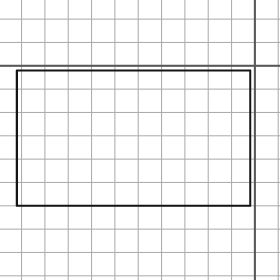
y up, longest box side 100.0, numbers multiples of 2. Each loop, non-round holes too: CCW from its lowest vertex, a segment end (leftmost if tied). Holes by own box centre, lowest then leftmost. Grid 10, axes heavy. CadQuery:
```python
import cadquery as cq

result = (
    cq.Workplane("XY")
    .moveTo(-102.0, -60.0)
    .lineTo(-2.0, -60.0)
    .lineTo(-2.0, -2.0)
    .lineTo(-102.0, -2.0)
    .close()
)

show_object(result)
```